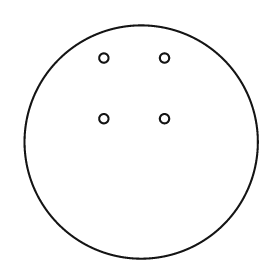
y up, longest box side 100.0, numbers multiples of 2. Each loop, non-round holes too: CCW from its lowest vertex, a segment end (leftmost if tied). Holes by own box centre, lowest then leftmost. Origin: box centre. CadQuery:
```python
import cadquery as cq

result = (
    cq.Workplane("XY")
    .moveTo(0.0, 0.0)
    .circle(50.0)
    .moveTo(-16.0, 10.0)
    .circle(2.0)
    .moveTo(10.0, 10.0)
    .circle(2.0)
    .moveTo(-16.0, 36.0)
    .circle(2.0)
    .moveTo(10.0, 36.0)
    .circle(2.0)
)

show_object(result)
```